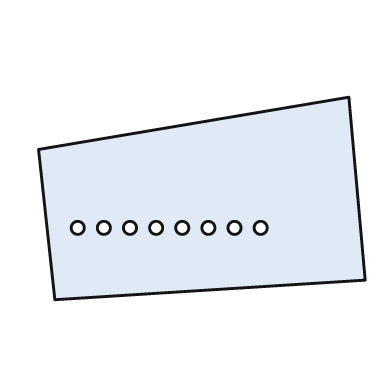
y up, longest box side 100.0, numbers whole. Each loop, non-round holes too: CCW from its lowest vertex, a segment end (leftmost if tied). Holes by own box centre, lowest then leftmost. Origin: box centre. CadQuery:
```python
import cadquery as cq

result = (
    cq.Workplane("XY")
    .moveTo(-45.0, -31.0)
    .lineTo(50.0, -25.0)
    .lineTo(45.0, 31.0)
    .lineTo(-50.0, 15.0)
    .close()
    .moveTo(-38.0, -9.0)
    .circle(2.0)
    .moveTo(-30.0, -9.0)
    .circle(2.0)
    .moveTo(-22.0, -9.0)
    .circle(2.0)
    .moveTo(-14.0, -9.0)
    .circle(2.0)
    .moveTo(-6.0, -9.0)
    .circle(2.0)
    .moveTo(2.0, -9.0)
    .circle(2.0)
    .moveTo(10.0, -9.0)
    .circle(2.0)
    .moveTo(18.0, -9.0)
    .circle(2.0)
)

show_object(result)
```